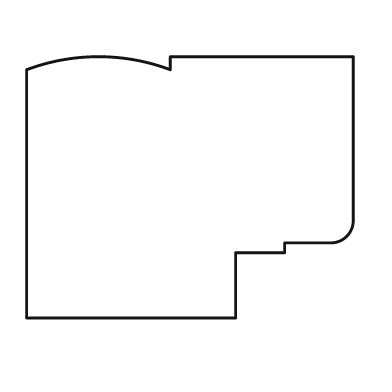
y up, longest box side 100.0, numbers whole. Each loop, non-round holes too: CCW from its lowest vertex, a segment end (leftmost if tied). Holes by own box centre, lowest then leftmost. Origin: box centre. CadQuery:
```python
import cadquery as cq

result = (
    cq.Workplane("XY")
    .moveTo(-50.0, -40.0)
    .lineTo(14.0, -40.0)
    .lineTo(14.0, -20.0)
    .lineTo(29.0, -20.0)
    .lineTo(29.0, -17.0)
    .lineTo(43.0, -17.0)
    .threePointArc((48.0, -15.0), (50.0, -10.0))
    .lineTo(50.0, 40.0)
    .lineTo(-6.0, 40.0)
    .lineTo(-6.0, 36.0)
    .threePointArc((-28.0, 40.0), (-50.0, 36.0))
    .close()
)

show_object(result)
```